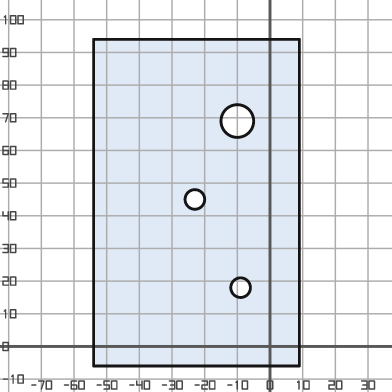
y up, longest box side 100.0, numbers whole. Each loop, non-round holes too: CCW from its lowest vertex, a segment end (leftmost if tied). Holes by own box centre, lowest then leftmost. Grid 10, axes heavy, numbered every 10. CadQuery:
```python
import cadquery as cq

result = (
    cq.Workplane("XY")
    .moveTo(-54.0, -6.0)
    .lineTo(9.0, -6.0)
    .lineTo(9.0, 94.0)
    .lineTo(-54.0, 94.0)
    .close()
    .moveTo(-9.0, 18.0)
    .circle(3.0)
    .moveTo(-23.0, 45.0)
    .circle(3.0)
    .moveTo(-10.0, 69.0)
    .circle(5.0)
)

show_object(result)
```